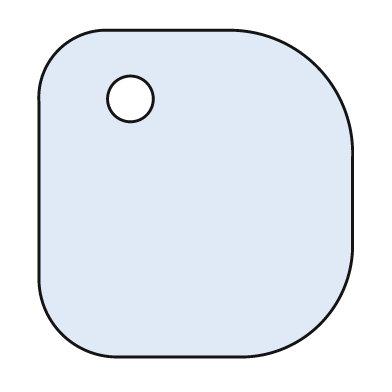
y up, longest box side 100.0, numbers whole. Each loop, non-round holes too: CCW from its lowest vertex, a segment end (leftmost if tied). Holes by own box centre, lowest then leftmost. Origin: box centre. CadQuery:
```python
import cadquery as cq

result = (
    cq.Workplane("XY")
    .moveTo(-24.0, -50.0)
    .lineTo(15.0, -50.0)
    .threePointArc((38.0, -40.0), (48.0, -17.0))
    .lineTo(48.0, 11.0)
    .threePointArc((37.0, 39.0), (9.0, 50.0))
    .lineTo(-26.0, 50.0)
    .threePointArc((-42.0, 44.0), (-48.0, 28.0))
    .lineTo(-48.0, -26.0)
    .threePointArc((-41.0, -43.0), (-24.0, -50.0))
    .close()
    .moveTo(-20.0, 29.0)
    .circle(7.0)
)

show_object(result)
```